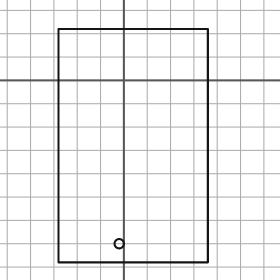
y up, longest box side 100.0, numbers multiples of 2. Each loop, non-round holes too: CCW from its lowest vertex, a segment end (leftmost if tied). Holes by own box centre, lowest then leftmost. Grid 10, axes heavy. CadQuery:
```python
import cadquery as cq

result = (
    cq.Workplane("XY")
    .moveTo(-28.0, -78.0)
    .lineTo(36.0, -78.0)
    .lineTo(36.0, 22.0)
    .lineTo(-28.0, 22.0)
    .close()
    .moveTo(-2.0, -70.0)
    .circle(2.0)
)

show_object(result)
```